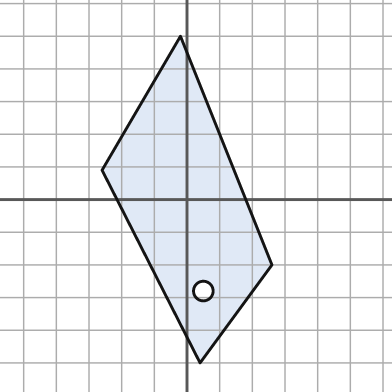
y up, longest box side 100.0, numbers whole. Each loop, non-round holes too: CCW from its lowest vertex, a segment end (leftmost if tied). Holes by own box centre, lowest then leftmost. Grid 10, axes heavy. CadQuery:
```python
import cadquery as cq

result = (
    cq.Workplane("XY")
    .moveTo(4.0, -50.0)
    .lineTo(26.0, -20.0)
    .lineTo(-2.0, 50.0)
    .lineTo(-26.0, 9.0)
    .close()
    .moveTo(5.0, -28.0)
    .circle(3.0)
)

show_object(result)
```